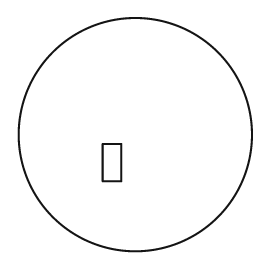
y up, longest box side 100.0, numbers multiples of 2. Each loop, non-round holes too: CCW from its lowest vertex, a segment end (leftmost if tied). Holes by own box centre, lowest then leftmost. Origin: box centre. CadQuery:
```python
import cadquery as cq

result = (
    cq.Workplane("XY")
    .moveTo(0.0, 0.0)
    .circle(50.0)
    .moveTo(-14.0, -20.0)
    .lineTo(-6.0, -20.0)
    .lineTo(-6.0, -4.0)
    .lineTo(-14.0, -4.0)
    .close()
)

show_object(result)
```